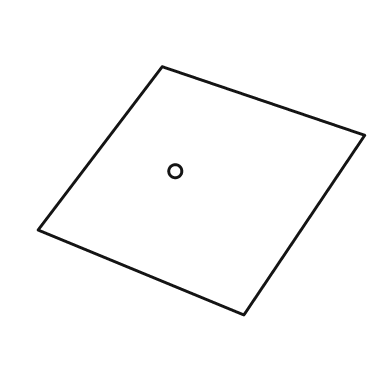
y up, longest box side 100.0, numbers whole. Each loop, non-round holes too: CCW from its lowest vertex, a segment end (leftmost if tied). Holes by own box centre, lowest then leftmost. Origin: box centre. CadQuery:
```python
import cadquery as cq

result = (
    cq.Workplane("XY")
    .moveTo(13.0, -38.0)
    .lineTo(50.0, 17.0)
    .lineTo(-12.0, 38.0)
    .lineTo(-50.0, -12.0)
    .close()
    .moveTo(-8.0, 6.0)
    .circle(2.0)
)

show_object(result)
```